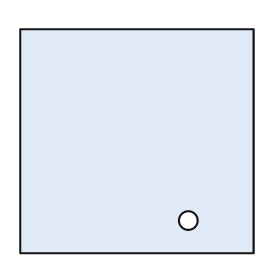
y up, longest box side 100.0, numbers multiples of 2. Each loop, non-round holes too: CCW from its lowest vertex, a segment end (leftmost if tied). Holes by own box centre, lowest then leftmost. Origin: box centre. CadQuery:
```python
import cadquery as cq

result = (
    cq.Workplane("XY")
    .moveTo(-50.0, -48.0)
    .lineTo(50.0, -48.0)
    .lineTo(50.0, 48.0)
    .lineTo(-50.0, 48.0)
    .close()
    .moveTo(22.0, -34.0)
    .circle(4.0)
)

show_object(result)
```